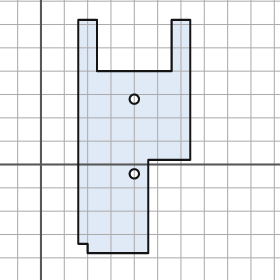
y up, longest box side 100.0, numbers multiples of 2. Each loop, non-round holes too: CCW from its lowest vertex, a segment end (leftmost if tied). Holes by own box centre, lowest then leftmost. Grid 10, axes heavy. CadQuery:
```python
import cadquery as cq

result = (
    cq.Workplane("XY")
    .moveTo(20.0, -38.0)
    .lineTo(46.0, -38.0)
    .lineTo(46.0, 2.0)
    .lineTo(64.0, 2.0)
    .lineTo(64.0, 62.0)
    .lineTo(56.0, 62.0)
    .lineTo(56.0, 40.0)
    .lineTo(24.0, 40.0)
    .lineTo(24.0, 62.0)
    .lineTo(16.0, 62.0)
    .lineTo(16.0, -34.0)
    .lineTo(20.0, -34.0)
    .close()
    .moveTo(40.0, -4.0)
    .circle(2.0)
    .moveTo(40.0, 28.0)
    .circle(2.0)
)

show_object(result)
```